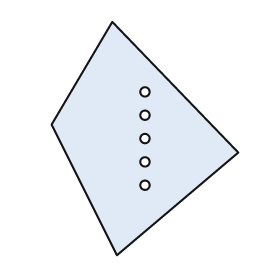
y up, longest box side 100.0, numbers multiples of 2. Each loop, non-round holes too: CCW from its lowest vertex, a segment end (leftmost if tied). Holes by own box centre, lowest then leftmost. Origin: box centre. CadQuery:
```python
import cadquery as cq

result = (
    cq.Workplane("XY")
    .moveTo(-12.0, -50.0)
    .lineTo(40.0, -6.0)
    .lineTo(-14.0, 50.0)
    .lineTo(-40.0, 6.0)
    .close()
    .moveTo(0.0, -20.0)
    .circle(2.0)
    .moveTo(0.0, -10.0)
    .circle(2.0)
    .moveTo(0.0, 0.0)
    .circle(2.0)
    .moveTo(0.0, 10.0)
    .circle(2.0)
    .moveTo(0.0, 20.0)
    .circle(2.0)
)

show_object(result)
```